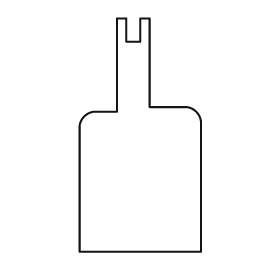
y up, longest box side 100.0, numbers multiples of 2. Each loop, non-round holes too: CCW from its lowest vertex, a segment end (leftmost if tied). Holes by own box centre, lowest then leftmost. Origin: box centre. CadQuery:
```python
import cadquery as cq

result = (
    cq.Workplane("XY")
    .moveTo(-26.0, -50.0)
    .lineTo(26.0, -50.0)
    .lineTo(26.0, 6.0)
    .threePointArc((24.0, 10.0), (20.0, 12.0))
    .lineTo(4.0, 12.0)
    .lineTo(4.0, 50.0)
    .lineTo(0.0, 50.0)
    .lineTo(0.0, 40.0)
    .lineTo(-6.0, 40.0)
    .lineTo(-6.0, 50.0)
    .lineTo(-10.0, 50.0)
    .lineTo(-10.0, 10.0)
    .lineTo(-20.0, 10.0)
    .threePointArc((-24.0, 8.0), (-26.0, 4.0))
    .close()
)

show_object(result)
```